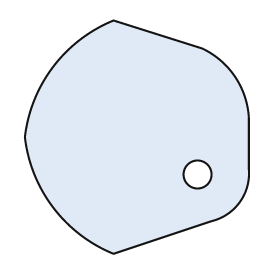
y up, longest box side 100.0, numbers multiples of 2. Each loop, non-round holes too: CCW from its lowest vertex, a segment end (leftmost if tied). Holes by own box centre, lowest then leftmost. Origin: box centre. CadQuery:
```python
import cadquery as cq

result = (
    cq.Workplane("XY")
    .moveTo(-10.0, -50.0)
    .lineTo(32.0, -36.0)
    .threePointArc((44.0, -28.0), (48.0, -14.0))
    .lineTo(48.0, 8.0)
    .threePointArc((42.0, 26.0), (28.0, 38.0))
    .lineTo(-10.0, 50.0)
    .threePointArc((-36.0, 30.0), (-48.0, 0.0))
    .threePointArc((-36.0, -30.0), (-10.0, -50.0))
    .close()
    .moveTo(26.0, -16.0)
    .circle(6.0)
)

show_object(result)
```